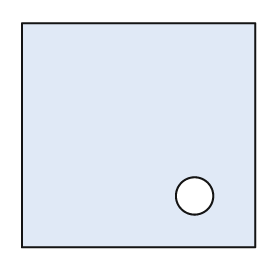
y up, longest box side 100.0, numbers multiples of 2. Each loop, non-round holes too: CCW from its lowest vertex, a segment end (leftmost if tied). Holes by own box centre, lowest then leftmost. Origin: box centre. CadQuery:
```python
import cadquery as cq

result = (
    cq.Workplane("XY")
    .moveTo(-50.0, -48.0)
    .lineTo(50.0, -48.0)
    .lineTo(50.0, 48.0)
    .lineTo(-50.0, 48.0)
    .close()
    .moveTo(24.0, -26.0)
    .circle(8.0)
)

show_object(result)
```